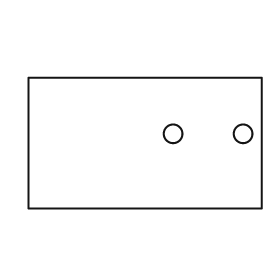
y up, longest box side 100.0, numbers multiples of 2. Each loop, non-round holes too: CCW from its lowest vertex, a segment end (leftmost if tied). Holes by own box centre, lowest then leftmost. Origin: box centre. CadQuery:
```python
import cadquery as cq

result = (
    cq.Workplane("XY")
    .moveTo(-50.0, -28.0)
    .lineTo(50.0, -28.0)
    .lineTo(50.0, 28.0)
    .lineTo(-50.0, 28.0)
    .close()
    .moveTo(12.0, 4.0)
    .circle(4.0)
    .moveTo(42.0, 4.0)
    .circle(4.0)
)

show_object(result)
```